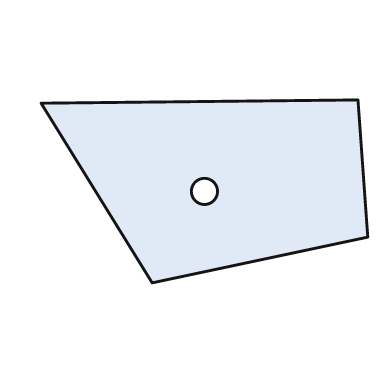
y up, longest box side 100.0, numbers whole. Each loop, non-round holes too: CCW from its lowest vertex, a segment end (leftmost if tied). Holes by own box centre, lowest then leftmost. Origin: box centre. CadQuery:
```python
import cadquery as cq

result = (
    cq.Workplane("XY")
    .moveTo(-16.0, -28.0)
    .lineTo(50.0, -14.0)
    .lineTo(47.0, 28.0)
    .lineTo(-50.0, 27.0)
    .close()
    .moveTo(0.0, 0.0)
    .circle(4.0)
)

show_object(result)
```